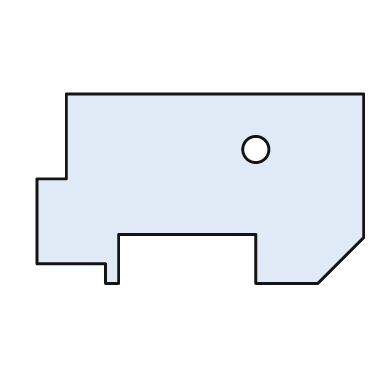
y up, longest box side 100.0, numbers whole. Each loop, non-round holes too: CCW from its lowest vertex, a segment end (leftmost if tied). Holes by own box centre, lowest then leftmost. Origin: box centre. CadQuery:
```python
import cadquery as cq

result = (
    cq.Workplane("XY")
    .moveTo(-29.0, -29.0)
    .lineTo(-25.0, -29.0)
    .lineTo(-25.0, -14.0)
    .lineTo(17.0, -14.0)
    .lineTo(17.0, -29.0)
    .lineTo(36.0, -29.0)
    .lineTo(50.0, -15.0)
    .lineTo(50.0, 29.0)
    .lineTo(-41.0, 29.0)
    .lineTo(-41.0, 3.0)
    .lineTo(-50.0, 3.0)
    .lineTo(-50.0, -23.0)
    .lineTo(-29.0, -23.0)
    .close()
    .moveTo(17.0, 12.0)
    .circle(4.0)
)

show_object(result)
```